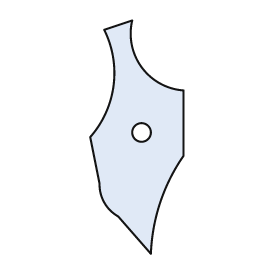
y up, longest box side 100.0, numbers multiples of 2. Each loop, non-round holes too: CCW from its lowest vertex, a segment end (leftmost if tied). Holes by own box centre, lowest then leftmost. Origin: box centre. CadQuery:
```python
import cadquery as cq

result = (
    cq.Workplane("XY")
    .moveTo(6.0, -50.0)
    .threePointArc((10.0, -28.0), (20.0, -8.0))
    .lineTo(20.0, 20.0)
    .threePointArc((2.0, 30.0), (-2.0, 50.0))
    .lineTo(-14.0, 46.0)
    .threePointArc((-10.0, 22.0), (-20.0, 0.0))
    .lineTo(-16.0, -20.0)
    .threePointArc((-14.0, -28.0), (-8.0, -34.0))
    .close()
    .moveTo(2.0, 2.0)
    .circle(4.0)
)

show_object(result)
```